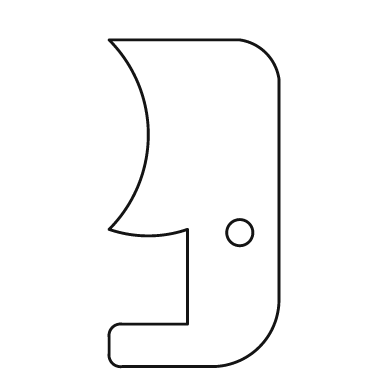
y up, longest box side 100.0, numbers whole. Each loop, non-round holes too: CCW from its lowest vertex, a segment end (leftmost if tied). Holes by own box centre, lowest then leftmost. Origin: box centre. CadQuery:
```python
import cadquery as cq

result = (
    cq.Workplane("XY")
    .moveTo(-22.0, -50.0)
    .lineTo(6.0, -50.0)
    .threePointArc((20.0, -44.0), (26.0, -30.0))
    .lineTo(26.0, 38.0)
    .threePointArc((22.0, 46.0), (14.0, 50.0))
    .lineTo(-26.0, 50.0)
    .threePointArc((-14.0, 21.0), (-26.0, -8.0))
    .threePointArc((-14.0, -10.0), (-2.0, -8.0))
    .lineTo(-2.0, -37.0)
    .lineTo(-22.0, -37.0)
    .threePointArc((-25.0, -38.0), (-26.0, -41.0))
    .lineTo(-26.0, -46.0)
    .threePointArc((-25.0, -49.0), (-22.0, -50.0))
    .close()
    .moveTo(14.0, -9.0)
    .circle(4.0)
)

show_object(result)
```